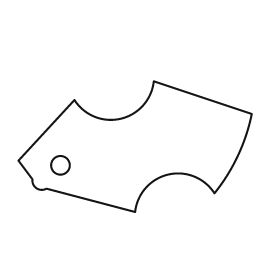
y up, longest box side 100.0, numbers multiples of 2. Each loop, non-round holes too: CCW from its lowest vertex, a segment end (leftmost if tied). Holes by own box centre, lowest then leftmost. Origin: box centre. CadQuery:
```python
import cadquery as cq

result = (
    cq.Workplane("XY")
    .moveTo(0.0, -28.0)
    .threePointArc((14.0, -12.0), (34.0, -20.0))
    .threePointArc((44.0, -4.0), (50.0, 14.0))
    .lineTo(8.0, 28.0)
    .threePointArc((-6.0, 12.0), (-26.0, 20.0))
    .lineTo(-50.0, -6.0)
    .lineTo(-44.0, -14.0)
    .threePointArc((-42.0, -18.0), (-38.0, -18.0))
    .close()
    .moveTo(-32.0, -8.0)
    .circle(4.0)
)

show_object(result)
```